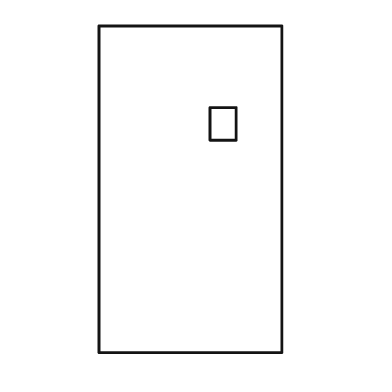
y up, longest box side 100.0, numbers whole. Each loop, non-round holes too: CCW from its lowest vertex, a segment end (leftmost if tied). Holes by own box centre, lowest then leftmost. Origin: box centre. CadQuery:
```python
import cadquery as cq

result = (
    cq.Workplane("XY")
    .moveTo(-28.0, -50.0)
    .lineTo(28.0, -50.0)
    .lineTo(28.0, 50.0)
    .lineTo(-28.0, 50.0)
    .close()
    .moveTo(6.0, 15.0)
    .lineTo(14.0, 15.0)
    .lineTo(14.0, 25.0)
    .lineTo(6.0, 25.0)
    .close()
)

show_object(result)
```